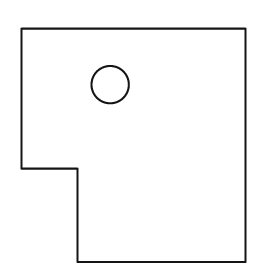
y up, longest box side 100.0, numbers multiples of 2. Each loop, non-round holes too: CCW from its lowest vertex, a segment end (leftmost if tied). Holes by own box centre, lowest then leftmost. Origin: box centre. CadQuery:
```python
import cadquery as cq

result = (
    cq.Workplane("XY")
    .moveTo(-24.0, -50.0)
    .lineTo(48.0, -50.0)
    .lineTo(48.0, 50.0)
    .lineTo(-48.0, 50.0)
    .lineTo(-48.0, -10.0)
    .lineTo(-24.0, -10.0)
    .close()
    .moveTo(-10.0, 26.0)
    .circle(8.0)
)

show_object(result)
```